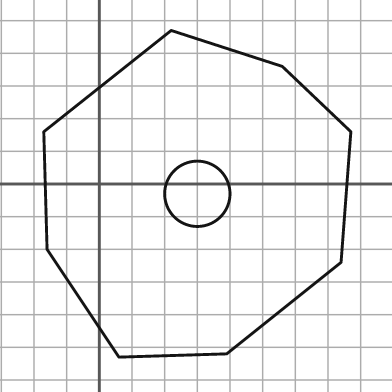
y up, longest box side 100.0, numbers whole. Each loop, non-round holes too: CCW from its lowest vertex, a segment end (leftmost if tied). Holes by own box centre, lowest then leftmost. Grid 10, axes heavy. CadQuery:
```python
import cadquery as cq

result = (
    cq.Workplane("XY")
    .moveTo(6.0, -53.0)
    .lineTo(39.0, -52.0)
    .lineTo(74.0, -24.0)
    .lineTo(77.0, 16.0)
    .lineTo(56.0, 36.0)
    .lineTo(22.0, 47.0)
    .lineTo(-17.0, 16.0)
    .lineTo(-16.0, -20.0)
    .close()
    .moveTo(30.0, -3.0)
    .circle(10.0)
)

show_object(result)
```